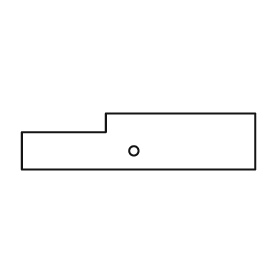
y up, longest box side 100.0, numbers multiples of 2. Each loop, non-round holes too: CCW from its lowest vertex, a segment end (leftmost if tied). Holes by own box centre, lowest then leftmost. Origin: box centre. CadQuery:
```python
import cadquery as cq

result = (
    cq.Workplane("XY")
    .moveTo(-50.0, -12.0)
    .lineTo(50.0, -12.0)
    .lineTo(50.0, 12.0)
    .lineTo(-14.0, 12.0)
    .lineTo(-14.0, 4.0)
    .lineTo(-50.0, 4.0)
    .close()
    .moveTo(-2.0, -4.0)
    .circle(2.0)
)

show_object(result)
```